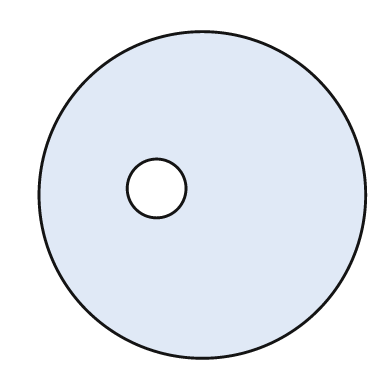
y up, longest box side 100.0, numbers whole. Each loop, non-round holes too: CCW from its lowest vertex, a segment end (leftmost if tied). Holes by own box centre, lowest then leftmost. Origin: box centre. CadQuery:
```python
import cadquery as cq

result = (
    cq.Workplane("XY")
    .moveTo(0.0, 0.0)
    .circle(50.0)
    .moveTo(-14.0, 2.0)
    .circle(9.0)
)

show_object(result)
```